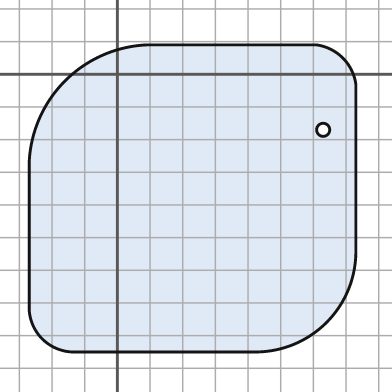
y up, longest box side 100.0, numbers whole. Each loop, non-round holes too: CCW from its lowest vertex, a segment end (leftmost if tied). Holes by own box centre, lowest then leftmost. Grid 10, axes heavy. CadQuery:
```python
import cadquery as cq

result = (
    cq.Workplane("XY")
    .moveTo(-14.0, -85.0)
    .lineTo(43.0, -85.0)
    .threePointArc((64.0, -76.0), (73.0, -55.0))
    .lineTo(73.0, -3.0)
    .threePointArc((69.0, 5.0), (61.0, 9.0))
    .lineTo(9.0, 9.0)
    .threePointArc((-16.0, -2.0), (-27.0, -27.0))
    .lineTo(-27.0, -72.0)
    .threePointArc((-23.0, -81.0), (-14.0, -85.0))
    .close()
    .moveTo(63.0, -17.0)
    .circle(2.0)
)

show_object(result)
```